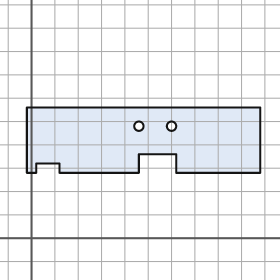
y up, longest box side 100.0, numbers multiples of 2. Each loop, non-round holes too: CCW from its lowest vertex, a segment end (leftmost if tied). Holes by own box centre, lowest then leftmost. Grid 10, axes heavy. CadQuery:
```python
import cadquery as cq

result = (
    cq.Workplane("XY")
    .moveTo(-2.0, 28.0)
    .lineTo(2.0, 28.0)
    .lineTo(2.0, 32.0)
    .lineTo(12.0, 32.0)
    .lineTo(12.0, 28.0)
    .lineTo(46.0, 28.0)
    .lineTo(46.0, 36.0)
    .lineTo(62.0, 36.0)
    .lineTo(62.0, 28.0)
    .lineTo(98.0, 28.0)
    .lineTo(98.0, 56.0)
    .lineTo(-2.0, 56.0)
    .close()
    .moveTo(46.0, 48.0)
    .circle(2.0)
    .moveTo(60.0, 48.0)
    .circle(2.0)
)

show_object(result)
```